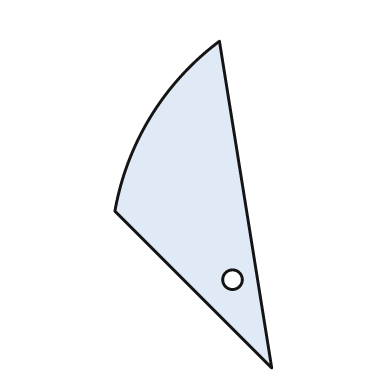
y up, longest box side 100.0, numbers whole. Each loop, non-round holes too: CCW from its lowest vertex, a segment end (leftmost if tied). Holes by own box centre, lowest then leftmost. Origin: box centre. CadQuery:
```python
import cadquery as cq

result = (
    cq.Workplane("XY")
    .moveTo(24.0, -50.0)
    .lineTo(8.0, 50.0)
    .threePointArc((-13.0, 27.0), (-24.0, -2.0))
    .close()
    .moveTo(12.0, -23.0)
    .circle(3.0)
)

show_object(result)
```